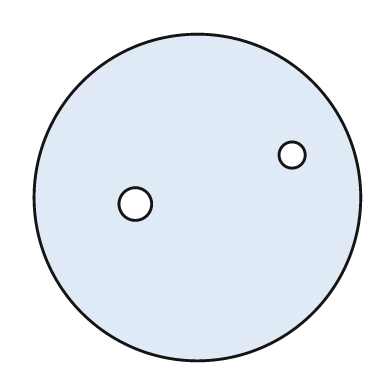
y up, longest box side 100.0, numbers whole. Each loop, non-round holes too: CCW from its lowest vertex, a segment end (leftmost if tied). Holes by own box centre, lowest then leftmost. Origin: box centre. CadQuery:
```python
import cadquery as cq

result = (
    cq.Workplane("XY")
    .moveTo(0.0, 0.0)
    .circle(50.0)
    .moveTo(-19.0, -2.0)
    .circle(5.0)
    .moveTo(29.0, 13.0)
    .circle(4.0)
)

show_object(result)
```